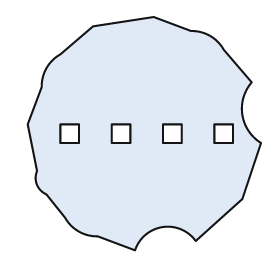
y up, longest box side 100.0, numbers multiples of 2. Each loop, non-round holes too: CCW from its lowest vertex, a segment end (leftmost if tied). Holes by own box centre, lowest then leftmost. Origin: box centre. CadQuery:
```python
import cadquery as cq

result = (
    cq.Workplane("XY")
    .moveTo(-4.0, -50.0)
    .threePointArc((8.0, -40.0), (22.0, -46.0))
    .lineTo(42.0, -28.0)
    .lineTo(50.0, -4.0)
    .threePointArc((42.0, 8.0), (46.0, 22.0))
    .lineTo(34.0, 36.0)
    .threePointArc((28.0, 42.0), (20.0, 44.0))
    .lineTo(4.0, 50.0)
    .lineTo(-22.0, 46.0)
    .lineTo(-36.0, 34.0)
    .threePointArc((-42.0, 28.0), (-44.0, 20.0))
    .lineTo(-50.0, 4.0)
    .lineTo(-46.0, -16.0)
    .threePointArc((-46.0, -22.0), (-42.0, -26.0))
    .lineTo(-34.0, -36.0)
    .threePointArc((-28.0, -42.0), (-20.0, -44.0))
    .close()
    .moveTo(-36.0, -4.0)
    .lineTo(-28.0, -4.0)
    .lineTo(-28.0, 4.0)
    .lineTo(-36.0, 4.0)
    .close()
    .moveTo(-14.0, -4.0)
    .lineTo(-6.0, -4.0)
    .lineTo(-6.0, 4.0)
    .lineTo(-14.0, 4.0)
    .close()
    .moveTo(8.0, -4.0)
    .lineTo(16.0, -4.0)
    .lineTo(16.0, 4.0)
    .lineTo(8.0, 4.0)
    .close()
    .moveTo(30.0, -4.0)
    .lineTo(38.0, -4.0)
    .lineTo(38.0, 4.0)
    .lineTo(30.0, 4.0)
    .close()
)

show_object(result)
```